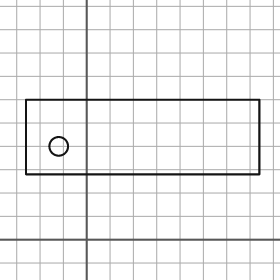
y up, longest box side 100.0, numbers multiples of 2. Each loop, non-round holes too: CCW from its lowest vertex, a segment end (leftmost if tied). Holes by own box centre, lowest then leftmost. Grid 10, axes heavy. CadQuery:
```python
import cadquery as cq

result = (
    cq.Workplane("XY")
    .moveTo(-26.0, 28.0)
    .lineTo(74.0, 28.0)
    .lineTo(74.0, 60.0)
    .lineTo(-26.0, 60.0)
    .close()
    .moveTo(-12.0, 40.0)
    .circle(4.0)
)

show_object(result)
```